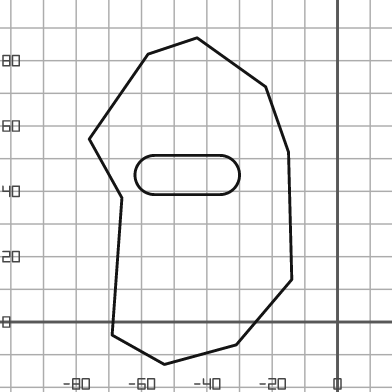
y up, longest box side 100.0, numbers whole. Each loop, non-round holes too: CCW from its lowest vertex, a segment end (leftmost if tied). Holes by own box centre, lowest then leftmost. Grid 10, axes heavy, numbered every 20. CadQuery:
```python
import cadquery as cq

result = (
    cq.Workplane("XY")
    .moveTo(-53.0, -13.0)
    .lineTo(-31.0, -7.0)
    .lineTo(-14.0, 13.0)
    .lineTo(-15.0, 52.0)
    .lineTo(-22.0, 72.0)
    .lineTo(-43.0, 87.0)
    .lineTo(-58.0, 82.0)
    .lineTo(-76.0, 56.0)
    .lineTo(-66.0, 38.0)
    .lineTo(-69.0, -4.0)
    .close()
    .moveTo(-56.0, 39.0)
    .lineTo(-36.0, 39.0)
    .threePointArc((-30.0, 45.0), (-36.0, 51.0))
    .lineTo(-56.0, 51.0)
    .threePointArc((-62.0, 45.0), (-56.0, 39.0))
    .close()
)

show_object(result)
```